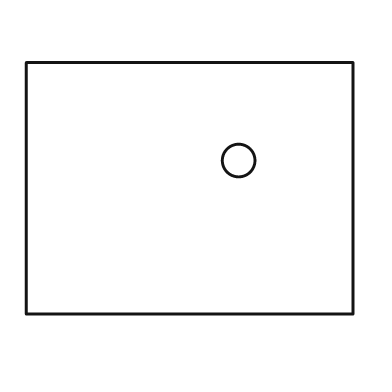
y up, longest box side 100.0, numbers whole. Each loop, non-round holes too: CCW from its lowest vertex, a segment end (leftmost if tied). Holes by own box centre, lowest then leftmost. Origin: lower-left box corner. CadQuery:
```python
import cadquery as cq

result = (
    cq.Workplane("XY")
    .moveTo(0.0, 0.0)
    .lineTo(100.0, 0.0)
    .lineTo(100.0, 77.0)
    .lineTo(0.0, 77.0)
    .close()
    .moveTo(65.0, 47.0)
    .circle(5.0)
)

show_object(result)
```